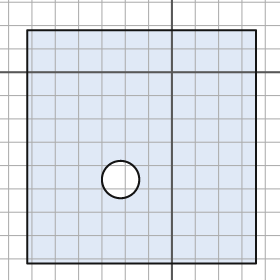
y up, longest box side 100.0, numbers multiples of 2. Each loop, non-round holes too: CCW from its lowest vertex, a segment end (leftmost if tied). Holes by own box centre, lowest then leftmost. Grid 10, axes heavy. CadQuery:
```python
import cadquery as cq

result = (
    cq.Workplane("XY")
    .moveTo(-62.0, -82.0)
    .lineTo(36.0, -82.0)
    .lineTo(36.0, 18.0)
    .lineTo(-62.0, 18.0)
    .close()
    .moveTo(-22.0, -46.0)
    .circle(8.0)
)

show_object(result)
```